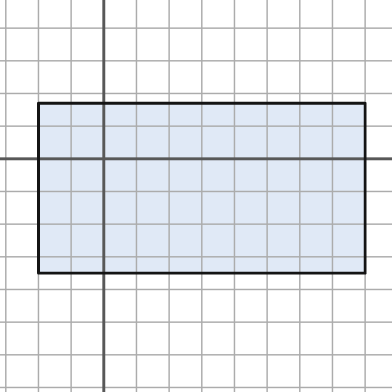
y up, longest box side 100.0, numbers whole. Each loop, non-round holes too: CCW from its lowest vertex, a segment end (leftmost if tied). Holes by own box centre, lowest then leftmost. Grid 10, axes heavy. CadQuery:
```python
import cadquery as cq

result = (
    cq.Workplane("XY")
    .moveTo(-20.0, -35.0)
    .lineTo(80.0, -35.0)
    .lineTo(80.0, 17.0)
    .lineTo(-20.0, 17.0)
    .close()
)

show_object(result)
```